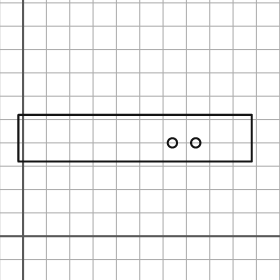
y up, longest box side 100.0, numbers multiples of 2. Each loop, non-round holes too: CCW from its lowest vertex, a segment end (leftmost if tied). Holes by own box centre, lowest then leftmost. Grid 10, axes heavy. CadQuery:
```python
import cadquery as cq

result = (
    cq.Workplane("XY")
    .moveTo(-2.0, 32.0)
    .lineTo(98.0, 32.0)
    .lineTo(98.0, 52.0)
    .lineTo(-2.0, 52.0)
    .close()
    .moveTo(64.0, 40.0)
    .circle(2.0)
    .moveTo(74.0, 40.0)
    .circle(2.0)
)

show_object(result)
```